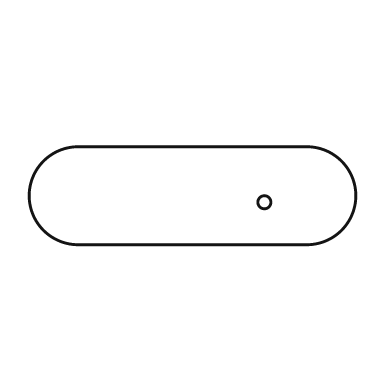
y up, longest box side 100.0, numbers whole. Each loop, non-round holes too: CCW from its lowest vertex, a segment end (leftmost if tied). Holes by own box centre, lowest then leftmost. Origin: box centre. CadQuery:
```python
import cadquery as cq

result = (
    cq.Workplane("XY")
    .moveTo(-35.0, -15.0)
    .lineTo(35.0, -15.0)
    .threePointArc((50.0, 0.0), (35.0, 15.0))
    .lineTo(-35.0, 15.0)
    .threePointArc((-50.0, 0.0), (-35.0, -15.0))
    .close()
    .moveTo(22.0, -2.0)
    .circle(2.0)
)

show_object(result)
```